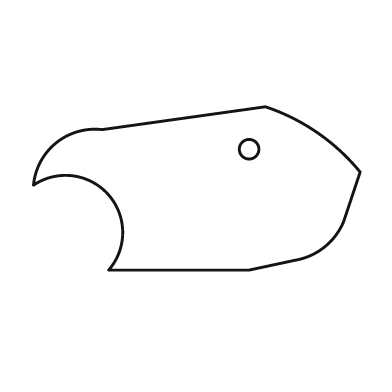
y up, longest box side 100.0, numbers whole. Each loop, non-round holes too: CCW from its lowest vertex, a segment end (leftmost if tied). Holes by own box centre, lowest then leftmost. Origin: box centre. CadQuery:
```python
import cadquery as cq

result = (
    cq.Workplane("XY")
    .moveTo(-27.0, -25.0)
    .lineTo(16.0, -25.0)
    .lineTo(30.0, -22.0)
    .threePointArc((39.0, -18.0), (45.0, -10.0))
    .lineTo(50.0, 5.0)
    .threePointArc((37.0, 17.0), (21.0, 25.0))
    .lineTo(-29.0, 18.0)
    .threePointArc((-43.0, 14.0), (-50.0, 1.0))
    .threePointArc((-27.0, -2.0), (-27.0, -25.0))
    .close()
    .moveTo(16.0, 12.0)
    .circle(3.0)
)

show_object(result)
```